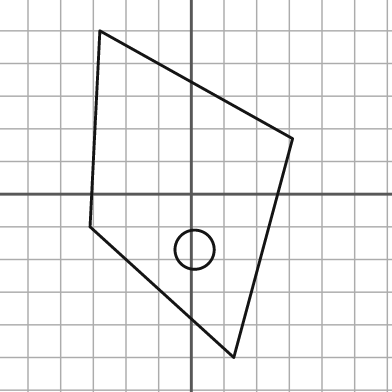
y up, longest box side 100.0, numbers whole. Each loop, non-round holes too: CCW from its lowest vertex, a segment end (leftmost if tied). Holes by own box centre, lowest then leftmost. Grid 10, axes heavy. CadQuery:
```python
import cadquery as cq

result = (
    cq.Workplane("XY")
    .moveTo(13.0, -50.0)
    .lineTo(31.0, 17.0)
    .lineTo(-28.0, 50.0)
    .lineTo(-31.0, -10.0)
    .close()
    .moveTo(1.0, -17.0)
    .circle(6.0)
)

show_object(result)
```